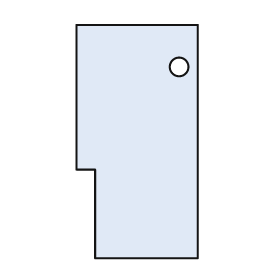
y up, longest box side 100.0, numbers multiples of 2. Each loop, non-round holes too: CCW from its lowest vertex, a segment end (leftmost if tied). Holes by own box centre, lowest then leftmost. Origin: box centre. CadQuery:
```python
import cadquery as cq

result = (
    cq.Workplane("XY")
    .moveTo(-18.0, -50.0)
    .lineTo(26.0, -50.0)
    .lineTo(26.0, 50.0)
    .lineTo(-26.0, 50.0)
    .lineTo(-26.0, -12.0)
    .lineTo(-18.0, -12.0)
    .close()
    .moveTo(18.0, 32.0)
    .circle(4.0)
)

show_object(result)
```